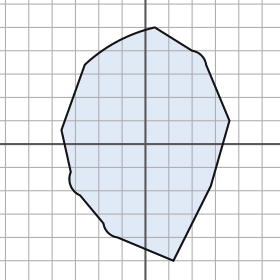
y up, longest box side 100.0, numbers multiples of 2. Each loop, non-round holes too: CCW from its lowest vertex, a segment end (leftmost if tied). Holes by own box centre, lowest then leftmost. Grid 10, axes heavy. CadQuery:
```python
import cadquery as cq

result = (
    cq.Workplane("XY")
    .moveTo(12.0, -50.0)
    .lineTo(28.0, -18.0)
    .lineTo(36.0, 10.0)
    .lineTo(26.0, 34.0)
    .threePointArc((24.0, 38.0), (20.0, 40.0))
    .lineTo(4.0, 50.0)
    .threePointArc((-12.0, 44.0), (-26.0, 34.0))
    .lineTo(-36.0, 6.0)
    .lineTo(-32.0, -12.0)
    .threePointArc((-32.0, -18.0), (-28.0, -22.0))
    .lineTo(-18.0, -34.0)
    .threePointArc((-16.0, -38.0), (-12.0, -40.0))
    .close()
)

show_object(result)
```